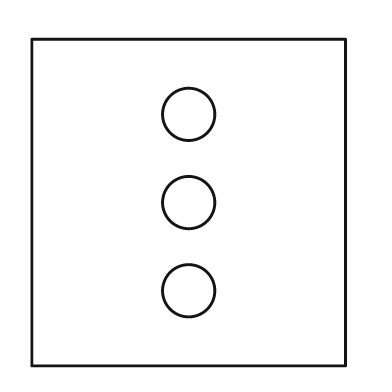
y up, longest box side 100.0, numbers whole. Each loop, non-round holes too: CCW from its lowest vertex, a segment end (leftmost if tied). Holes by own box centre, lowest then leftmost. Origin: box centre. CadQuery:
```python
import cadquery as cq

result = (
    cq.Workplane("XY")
    .moveTo(-48.0, -50.0)
    .lineTo(48.0, -50.0)
    .lineTo(48.0, 50.0)
    .lineTo(-48.0, 50.0)
    .close()
    .moveTo(0.0, -27.0)
    .circle(8.0)
    .moveTo(0.0, 0.0)
    .circle(8.0)
    .moveTo(0.0, 27.0)
    .circle(8.0)
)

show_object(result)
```